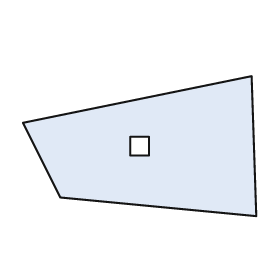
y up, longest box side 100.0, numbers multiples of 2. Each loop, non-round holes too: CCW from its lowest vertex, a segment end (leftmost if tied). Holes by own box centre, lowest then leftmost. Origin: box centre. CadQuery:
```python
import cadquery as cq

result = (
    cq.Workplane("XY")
    .moveTo(50.0, -30.0)
    .lineTo(48.0, 30.0)
    .lineTo(-50.0, 10.0)
    .lineTo(-34.0, -22.0)
    .close()
    .moveTo(-4.0, -4.0)
    .lineTo(4.0, -4.0)
    .lineTo(4.0, 4.0)
    .lineTo(-4.0, 4.0)
    .close()
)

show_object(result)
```